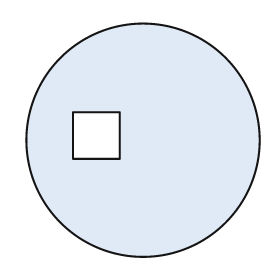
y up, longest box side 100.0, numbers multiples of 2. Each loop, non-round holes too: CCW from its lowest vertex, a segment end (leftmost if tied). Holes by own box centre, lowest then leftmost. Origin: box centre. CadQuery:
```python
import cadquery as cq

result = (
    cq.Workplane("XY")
    .moveTo(0.0, 0.0)
    .circle(50.0)
    .moveTo(-30.0, -8.0)
    .lineTo(-10.0, -8.0)
    .lineTo(-10.0, 12.0)
    .lineTo(-30.0, 12.0)
    .close()
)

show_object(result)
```